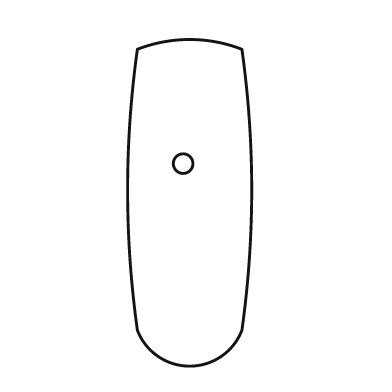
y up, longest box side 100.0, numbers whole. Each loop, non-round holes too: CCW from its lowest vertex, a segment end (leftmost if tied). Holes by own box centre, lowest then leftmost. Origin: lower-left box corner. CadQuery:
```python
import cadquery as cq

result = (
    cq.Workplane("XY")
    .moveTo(3.0, 11.0)
    .threePointArc((19.0, 0.0), (35.0, 11.0))
    .threePointArc((38.0, 54.0), (35.0, 97.0))
    .threePointArc((19.0, 100.0), (3.0, 97.0))
    .threePointArc((0.0, 54.0), (3.0, 11.0))
    .close()
    .moveTo(17.0, 62.0)
    .circle(3.0)
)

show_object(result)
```